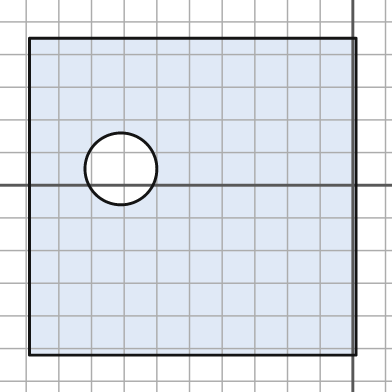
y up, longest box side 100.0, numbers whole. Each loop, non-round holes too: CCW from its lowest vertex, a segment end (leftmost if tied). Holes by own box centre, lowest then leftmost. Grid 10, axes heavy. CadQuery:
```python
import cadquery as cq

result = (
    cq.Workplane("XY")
    .moveTo(-99.0, -52.0)
    .lineTo(1.0, -52.0)
    .lineTo(1.0, 45.0)
    .lineTo(-99.0, 45.0)
    .close()
    .moveTo(-71.0, 5.0)
    .circle(11.0)
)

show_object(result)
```